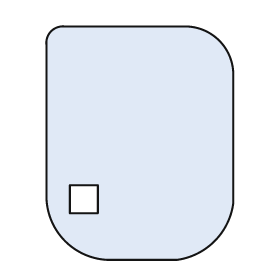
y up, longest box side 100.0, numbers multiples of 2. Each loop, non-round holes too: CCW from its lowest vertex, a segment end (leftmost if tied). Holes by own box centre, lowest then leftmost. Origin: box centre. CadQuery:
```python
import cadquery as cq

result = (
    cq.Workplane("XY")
    .moveTo(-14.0, -50.0)
    .lineTo(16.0, -50.0)
    .threePointArc((32.0, -42.0), (40.0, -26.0))
    .lineTo(40.0, 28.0)
    .threePointArc((34.0, 44.0), (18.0, 50.0))
    .lineTo(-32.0, 50.0)
    .threePointArc((-38.0, 48.0), (-40.0, 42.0))
    .lineTo(-40.0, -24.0)
    .threePointArc((-32.0, -42.0), (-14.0, -50.0))
    .close()
    .moveTo(-30.0, -30.0)
    .lineTo(-18.0, -30.0)
    .lineTo(-18.0, -18.0)
    .lineTo(-30.0, -18.0)
    .close()
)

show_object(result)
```